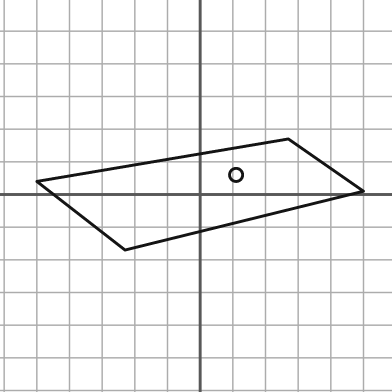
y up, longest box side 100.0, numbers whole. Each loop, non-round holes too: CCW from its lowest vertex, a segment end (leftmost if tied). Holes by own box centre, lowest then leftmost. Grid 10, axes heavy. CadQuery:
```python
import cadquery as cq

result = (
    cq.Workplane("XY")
    .moveTo(-23.0, -17.0)
    .lineTo(50.0, 1.0)
    .lineTo(27.0, 17.0)
    .lineTo(-50.0, 4.0)
    .close()
    .moveTo(11.0, 6.0)
    .circle(2.0)
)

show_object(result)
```